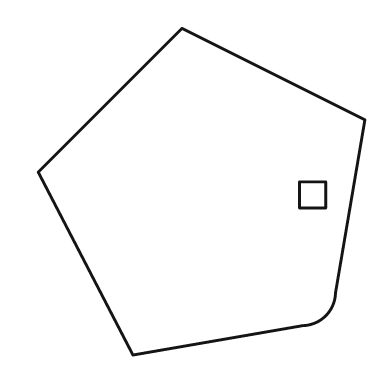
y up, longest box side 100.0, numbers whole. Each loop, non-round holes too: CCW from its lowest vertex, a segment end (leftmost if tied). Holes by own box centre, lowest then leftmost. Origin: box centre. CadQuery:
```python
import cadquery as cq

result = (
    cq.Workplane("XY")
    .moveTo(-21.0, -50.0)
    .lineTo(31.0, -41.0)
    .threePointArc((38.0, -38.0), (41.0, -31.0))
    .lineTo(50.0, 22.0)
    .lineTo(-6.0, 50.0)
    .lineTo(-50.0, 6.0)
    .close()
    .moveTo(30.0, -5.0)
    .lineTo(38.0, -5.0)
    .lineTo(38.0, 3.0)
    .lineTo(30.0, 3.0)
    .close()
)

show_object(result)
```